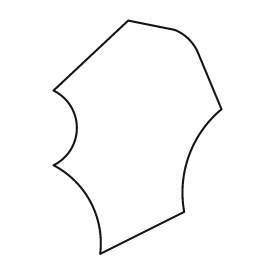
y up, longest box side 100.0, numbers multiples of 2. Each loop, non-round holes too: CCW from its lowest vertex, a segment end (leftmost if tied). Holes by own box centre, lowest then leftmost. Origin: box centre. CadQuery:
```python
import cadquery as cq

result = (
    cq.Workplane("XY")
    .moveTo(-16.0, -50.0)
    .lineTo(20.0, -32.0)
    .threePointArc((22.0, -8.0), (36.0, 12.0))
    .lineTo(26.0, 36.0)
    .threePointArc((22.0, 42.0), (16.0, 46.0))
    .lineTo(-4.0, 50.0)
    .lineTo(-36.0, 20.0)
    .threePointArc((-26.0, 4.0), (-36.0, -12.0))
    .threePointArc((-20.0, -28.0), (-16.0, -50.0))
    .close()
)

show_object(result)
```